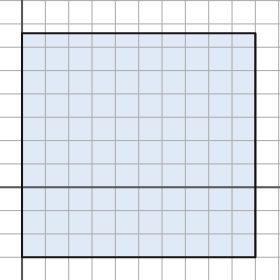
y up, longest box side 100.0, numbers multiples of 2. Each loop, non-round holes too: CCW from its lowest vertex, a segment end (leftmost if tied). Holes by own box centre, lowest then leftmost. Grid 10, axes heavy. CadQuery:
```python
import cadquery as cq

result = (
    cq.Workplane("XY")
    .moveTo(0.0, -30.0)
    .lineTo(100.0, -30.0)
    .lineTo(100.0, 66.0)
    .lineTo(0.0, 66.0)
    .close()
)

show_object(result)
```